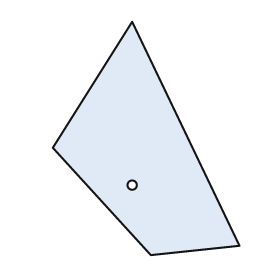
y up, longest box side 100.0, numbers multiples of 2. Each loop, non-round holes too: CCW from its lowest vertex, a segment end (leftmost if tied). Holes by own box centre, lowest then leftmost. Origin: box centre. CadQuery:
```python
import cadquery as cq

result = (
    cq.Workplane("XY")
    .moveTo(2.0, -50.0)
    .lineTo(40.0, -46.0)
    .lineTo(-6.0, 50.0)
    .lineTo(-40.0, -4.0)
    .close()
    .moveTo(-6.0, -20.0)
    .circle(2.0)
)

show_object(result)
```